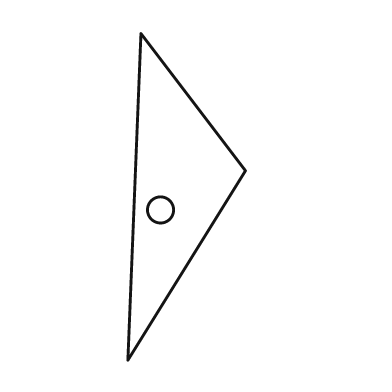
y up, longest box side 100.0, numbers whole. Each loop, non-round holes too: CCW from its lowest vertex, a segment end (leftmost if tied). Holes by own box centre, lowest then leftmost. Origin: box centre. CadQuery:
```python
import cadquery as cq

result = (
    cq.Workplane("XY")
    .moveTo(-18.0, -50.0)
    .lineTo(18.0, 8.0)
    .lineTo(-14.0, 50.0)
    .close()
    .moveTo(-8.0, -4.0)
    .circle(4.0)
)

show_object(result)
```